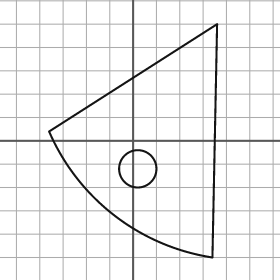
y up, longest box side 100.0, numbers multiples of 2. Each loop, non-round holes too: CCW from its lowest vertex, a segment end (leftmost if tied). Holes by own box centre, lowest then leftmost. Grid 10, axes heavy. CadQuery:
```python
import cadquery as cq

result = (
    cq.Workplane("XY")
    .moveTo(34.0, -50.0)
    .lineTo(36.0, 50.0)
    .lineTo(-36.0, 4.0)
    .threePointArc((-8.0, -32.0), (34.0, -50.0))
    .close()
    .moveTo(2.0, -12.0)
    .circle(8.0)
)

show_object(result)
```